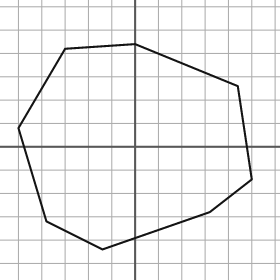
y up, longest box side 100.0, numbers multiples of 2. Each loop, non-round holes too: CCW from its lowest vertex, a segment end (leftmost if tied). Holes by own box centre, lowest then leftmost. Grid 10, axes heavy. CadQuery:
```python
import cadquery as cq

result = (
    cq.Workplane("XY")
    .moveTo(-14.0, -44.0)
    .lineTo(32.0, -28.0)
    .lineTo(50.0, -14.0)
    .lineTo(44.0, 26.0)
    .lineTo(0.0, 44.0)
    .lineTo(-30.0, 42.0)
    .lineTo(-50.0, 8.0)
    .lineTo(-38.0, -32.0)
    .close()
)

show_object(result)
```